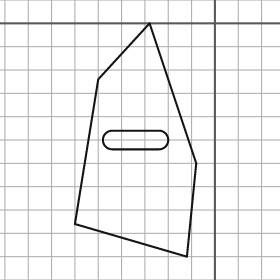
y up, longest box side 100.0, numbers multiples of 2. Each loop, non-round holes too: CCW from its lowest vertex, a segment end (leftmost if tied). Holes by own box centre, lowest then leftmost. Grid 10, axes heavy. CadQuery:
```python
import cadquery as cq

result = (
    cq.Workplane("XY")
    .moveTo(-12.0, -100.0)
    .lineTo(-8.0, -60.0)
    .lineTo(-28.0, 0.0)
    .lineTo(-50.0, -24.0)
    .lineTo(-60.0, -86.0)
    .close()
    .moveTo(-44.0, -54.0)
    .lineTo(-24.0, -54.0)
    .threePointArc((-20.0, -50.0), (-24.0, -46.0))
    .lineTo(-44.0, -46.0)
    .threePointArc((-48.0, -50.0), (-44.0, -54.0))
    .close()
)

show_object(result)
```